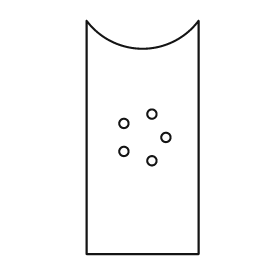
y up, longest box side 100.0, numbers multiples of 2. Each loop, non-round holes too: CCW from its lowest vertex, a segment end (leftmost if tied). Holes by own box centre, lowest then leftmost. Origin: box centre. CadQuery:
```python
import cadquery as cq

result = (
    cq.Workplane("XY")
    .moveTo(-24.0, -50.0)
    .lineTo(24.0, -50.0)
    .lineTo(24.0, 50.0)
    .threePointArc((0.0, 38.0), (-24.0, 50.0))
    .close()
    .moveTo(4.0, -10.0)
    .circle(2.0)
    .moveTo(-8.0, -6.0)
    .circle(2.0)
    .moveTo(10.0, 0.0)
    .circle(2.0)
    .moveTo(-8.0, 6.0)
    .circle(2.0)
    .moveTo(4.0, 10.0)
    .circle(2.0)
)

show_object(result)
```